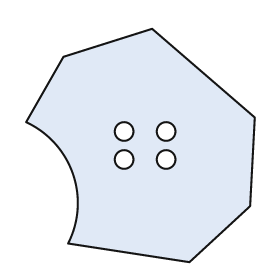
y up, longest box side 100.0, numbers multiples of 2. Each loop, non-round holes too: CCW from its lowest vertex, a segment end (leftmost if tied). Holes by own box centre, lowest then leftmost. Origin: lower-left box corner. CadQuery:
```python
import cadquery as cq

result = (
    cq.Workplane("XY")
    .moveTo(70.0, 0.0)
    .lineTo(96.0, 24.0)
    .lineTo(98.0, 62.0)
    .lineTo(54.0, 100.0)
    .lineTo(16.0, 88.0)
    .lineTo(0.0, 60.0)
    .threePointArc((20.0, 38.0), (18.0, 8.0))
    .close()
    .moveTo(42.0, 44.0)
    .circle(4.0)
    .moveTo(60.0, 44.0)
    .circle(4.0)
    .moveTo(42.0, 56.0)
    .circle(4.0)
    .moveTo(60.0, 56.0)
    .circle(4.0)
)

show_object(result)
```